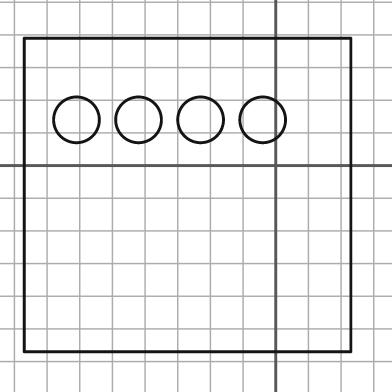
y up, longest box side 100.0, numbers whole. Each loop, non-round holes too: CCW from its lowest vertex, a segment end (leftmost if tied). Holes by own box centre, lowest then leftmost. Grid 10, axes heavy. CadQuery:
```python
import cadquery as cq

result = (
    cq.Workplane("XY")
    .moveTo(-77.0, -57.0)
    .lineTo(23.0, -57.0)
    .lineTo(23.0, 39.0)
    .lineTo(-77.0, 39.0)
    .close()
    .moveTo(-61.0, 14.0)
    .circle(7.0)
    .moveTo(-42.0, 14.0)
    .circle(7.0)
    .moveTo(-23.0, 14.0)
    .circle(7.0)
    .moveTo(-4.0, 14.0)
    .circle(7.0)
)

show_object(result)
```